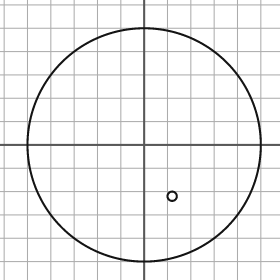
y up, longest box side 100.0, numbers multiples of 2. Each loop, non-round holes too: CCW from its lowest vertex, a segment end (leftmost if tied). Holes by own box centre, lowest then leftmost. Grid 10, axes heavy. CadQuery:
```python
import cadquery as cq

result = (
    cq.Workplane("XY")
    .moveTo(0.0, 0.0)
    .circle(50.0)
    .moveTo(12.0, -22.0)
    .circle(2.0)
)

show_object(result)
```